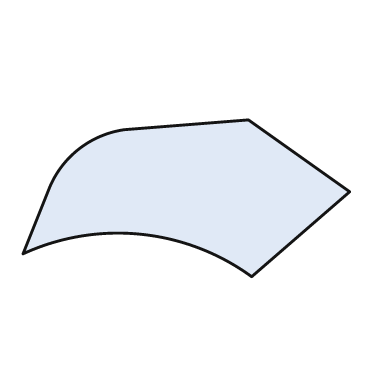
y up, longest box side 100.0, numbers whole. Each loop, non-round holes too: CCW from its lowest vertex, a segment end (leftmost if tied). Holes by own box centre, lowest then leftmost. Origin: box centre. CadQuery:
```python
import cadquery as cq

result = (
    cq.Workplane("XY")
    .moveTo(20.0, -24.0)
    .lineTo(50.0, 2.0)
    .lineTo(19.0, 24.0)
    .lineTo(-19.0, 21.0)
    .threePointArc((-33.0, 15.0), (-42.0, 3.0))
    .lineTo(-50.0, -17.0)
    .threePointArc((-14.0, -11.0), (20.0, -24.0))
    .close()
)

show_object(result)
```